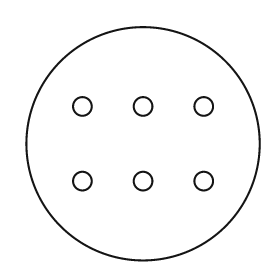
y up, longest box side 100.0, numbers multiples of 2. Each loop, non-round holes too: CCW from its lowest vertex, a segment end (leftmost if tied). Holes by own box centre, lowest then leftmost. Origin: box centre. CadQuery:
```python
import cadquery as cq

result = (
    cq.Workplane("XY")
    .moveTo(0.0, 0.0)
    .circle(50.0)
    .moveTo(-26.0, -16.0)
    .circle(4.0)
    .moveTo(0.0, -16.0)
    .circle(4.0)
    .moveTo(26.0, -16.0)
    .circle(4.0)
    .moveTo(-26.0, 16.0)
    .circle(4.0)
    .moveTo(0.0, 16.0)
    .circle(4.0)
    .moveTo(26.0, 16.0)
    .circle(4.0)
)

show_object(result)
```